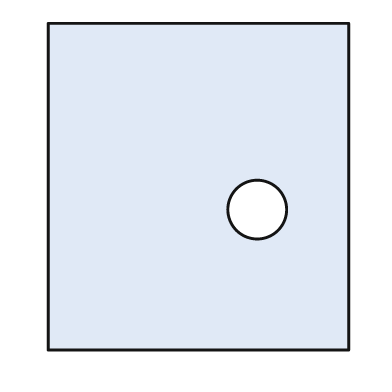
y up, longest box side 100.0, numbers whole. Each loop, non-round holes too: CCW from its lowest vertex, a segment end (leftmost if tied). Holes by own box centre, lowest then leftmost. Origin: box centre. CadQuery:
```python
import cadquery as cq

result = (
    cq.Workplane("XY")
    .moveTo(-46.0, -50.0)
    .lineTo(46.0, -50.0)
    .lineTo(46.0, 50.0)
    .lineTo(-46.0, 50.0)
    .close()
    .moveTo(18.0, -7.0)
    .circle(9.0)
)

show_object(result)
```